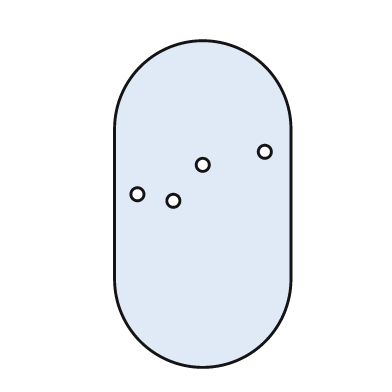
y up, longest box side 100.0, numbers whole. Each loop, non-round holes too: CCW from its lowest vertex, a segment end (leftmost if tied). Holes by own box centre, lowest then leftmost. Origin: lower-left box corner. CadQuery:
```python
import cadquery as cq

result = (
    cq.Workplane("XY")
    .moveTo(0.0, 27.0)
    .threePointArc((27.0, 0.0), (54.0, 27.0))
    .lineTo(54.0, 73.0)
    .threePointArc((27.0, 100.0), (0.0, 73.0))
    .close()
    .moveTo(18.0, 51.0)
    .circle(2.0)
    .moveTo(7.0, 53.0)
    .circle(2.0)
    .moveTo(27.0, 62.0)
    .circle(2.0)
    .moveTo(46.0, 66.0)
    .circle(2.0)
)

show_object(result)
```